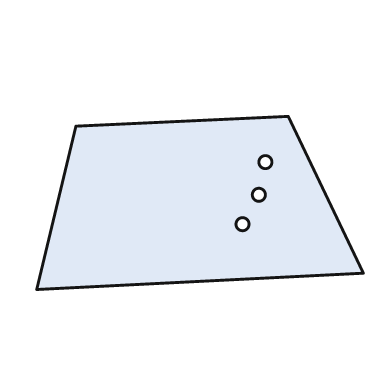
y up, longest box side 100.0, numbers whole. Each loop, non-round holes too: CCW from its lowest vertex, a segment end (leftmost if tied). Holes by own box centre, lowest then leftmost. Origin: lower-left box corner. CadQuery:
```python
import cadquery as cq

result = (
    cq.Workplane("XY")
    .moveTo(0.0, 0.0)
    .lineTo(100.0, 5.0)
    .lineTo(77.0, 53.0)
    .lineTo(12.0, 50.0)
    .close()
    .moveTo(63.0, 20.0)
    .circle(2.0)
    .moveTo(68.0, 29.0)
    .circle(2.0)
    .moveTo(70.0, 39.0)
    .circle(2.0)
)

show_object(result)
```